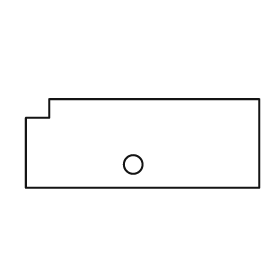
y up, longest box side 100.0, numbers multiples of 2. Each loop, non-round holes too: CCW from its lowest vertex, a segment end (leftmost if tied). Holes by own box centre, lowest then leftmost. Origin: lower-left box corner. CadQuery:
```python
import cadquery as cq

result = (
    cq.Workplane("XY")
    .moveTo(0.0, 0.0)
    .lineTo(100.0, 0.0)
    .lineTo(100.0, 38.0)
    .lineTo(10.0, 38.0)
    .lineTo(10.0, 30.0)
    .lineTo(0.0, 30.0)
    .close()
    .moveTo(46.0, 10.0)
    .circle(4.0)
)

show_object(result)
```